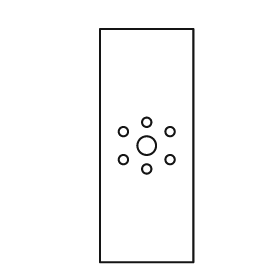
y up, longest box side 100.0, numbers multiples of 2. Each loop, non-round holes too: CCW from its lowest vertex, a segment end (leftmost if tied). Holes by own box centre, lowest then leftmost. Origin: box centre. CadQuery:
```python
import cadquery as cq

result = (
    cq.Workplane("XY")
    .moveTo(-20.0, -50.0)
    .lineTo(20.0, -50.0)
    .lineTo(20.0, 50.0)
    .lineTo(-20.0, 50.0)
    .close()
    .moveTo(0.0, -10.0)
    .circle(2.0)
    .moveTo(-10.0, -6.0)
    .circle(2.0)
    .moveTo(10.0, -6.0)
    .circle(2.0)
    .moveTo(0.0, 0.0)
    .circle(4.0)
    .moveTo(-10.0, 6.0)
    .circle(2.0)
    .moveTo(10.0, 6.0)
    .circle(2.0)
    .moveTo(0.0, 10.0)
    .circle(2.0)
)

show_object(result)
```